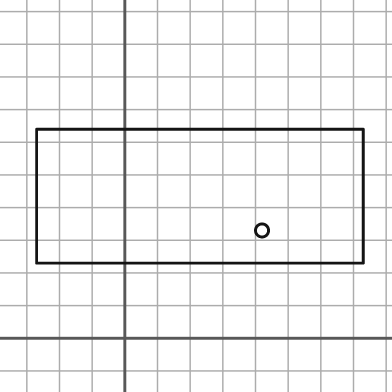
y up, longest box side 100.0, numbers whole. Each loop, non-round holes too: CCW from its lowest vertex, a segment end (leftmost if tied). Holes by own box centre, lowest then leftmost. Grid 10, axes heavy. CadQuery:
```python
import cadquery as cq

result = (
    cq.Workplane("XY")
    .moveTo(-27.0, 23.0)
    .lineTo(73.0, 23.0)
    .lineTo(73.0, 64.0)
    .lineTo(-27.0, 64.0)
    .close()
    .moveTo(42.0, 33.0)
    .circle(2.0)
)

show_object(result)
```